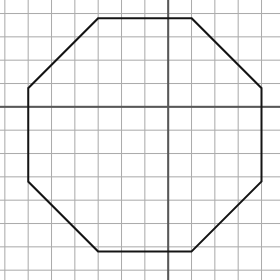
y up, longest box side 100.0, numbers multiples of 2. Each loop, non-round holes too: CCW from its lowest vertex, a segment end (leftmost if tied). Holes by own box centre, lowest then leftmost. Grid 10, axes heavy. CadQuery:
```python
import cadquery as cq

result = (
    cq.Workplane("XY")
    .moveTo(-30.0, -62.0)
    .lineTo(10.0, -62.0)
    .lineTo(40.0, -32.0)
    .lineTo(40.0, 8.0)
    .lineTo(10.0, 38.0)
    .lineTo(-30.0, 38.0)
    .lineTo(-60.0, 8.0)
    .lineTo(-60.0, -32.0)
    .close()
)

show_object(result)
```